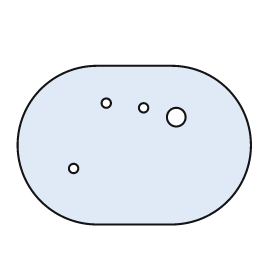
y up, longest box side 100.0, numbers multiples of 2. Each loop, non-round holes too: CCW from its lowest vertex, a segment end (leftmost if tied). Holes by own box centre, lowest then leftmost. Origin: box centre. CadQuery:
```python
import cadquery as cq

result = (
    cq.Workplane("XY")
    .moveTo(-16.0, -34.0)
    .lineTo(16.0, -34.0)
    .threePointArc((50.0, 0.0), (16.0, 34.0))
    .lineTo(-16.0, 34.0)
    .threePointArc((-50.0, 0.0), (-16.0, -34.0))
    .close()
    .moveTo(-26.0, -10.0)
    .circle(2.0)
    .moveTo(18.0, 12.0)
    .circle(4.0)
    .moveTo(4.0, 16.0)
    .circle(2.0)
    .moveTo(-12.0, 18.0)
    .circle(2.0)
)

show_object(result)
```